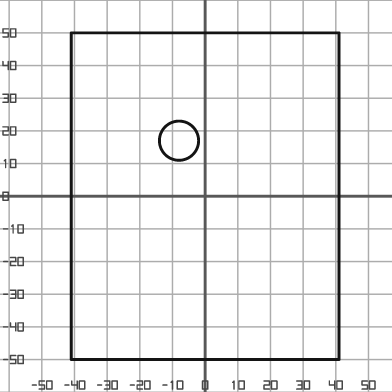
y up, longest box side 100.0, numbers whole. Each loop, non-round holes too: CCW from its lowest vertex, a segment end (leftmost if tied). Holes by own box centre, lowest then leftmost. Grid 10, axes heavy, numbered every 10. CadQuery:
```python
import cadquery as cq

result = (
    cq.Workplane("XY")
    .moveTo(-41.0, -50.0)
    .lineTo(41.0, -50.0)
    .lineTo(41.0, 50.0)
    .lineTo(-41.0, 50.0)
    .close()
    .moveTo(-8.0, 17.0)
    .circle(6.0)
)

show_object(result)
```